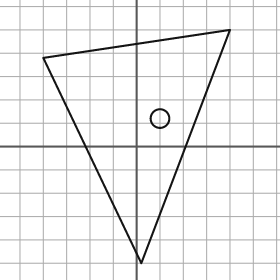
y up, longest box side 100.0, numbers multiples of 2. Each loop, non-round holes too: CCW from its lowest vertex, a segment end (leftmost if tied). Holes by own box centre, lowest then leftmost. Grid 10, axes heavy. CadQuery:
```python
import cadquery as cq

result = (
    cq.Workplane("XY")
    .moveTo(2.0, -50.0)
    .lineTo(40.0, 50.0)
    .lineTo(-40.0, 38.0)
    .close()
    .moveTo(10.0, 12.0)
    .circle(4.0)
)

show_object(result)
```